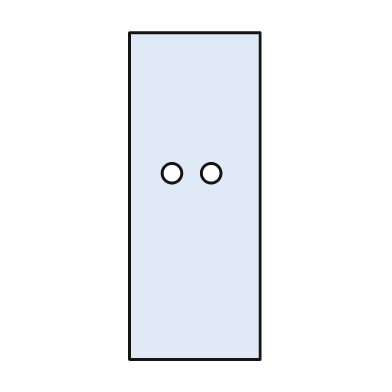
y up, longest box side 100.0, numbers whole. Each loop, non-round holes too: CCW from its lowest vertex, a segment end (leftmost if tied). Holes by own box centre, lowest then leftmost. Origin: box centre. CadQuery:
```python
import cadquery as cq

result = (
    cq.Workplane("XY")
    .moveTo(-20.0, -50.0)
    .lineTo(20.0, -50.0)
    .lineTo(20.0, 50.0)
    .lineTo(-20.0, 50.0)
    .close()
    .moveTo(-7.0, 7.0)
    .circle(3.0)
    .moveTo(5.0, 7.0)
    .circle(3.0)
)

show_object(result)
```